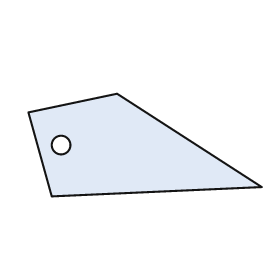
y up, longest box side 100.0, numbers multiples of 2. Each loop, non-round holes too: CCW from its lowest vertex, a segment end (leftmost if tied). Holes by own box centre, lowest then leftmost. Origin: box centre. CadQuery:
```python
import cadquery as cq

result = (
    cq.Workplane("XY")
    .moveTo(-40.0, -22.0)
    .lineTo(50.0, -18.0)
    .lineTo(-12.0, 22.0)
    .lineTo(-50.0, 14.0)
    .close()
    .moveTo(-36.0, 0.0)
    .circle(4.0)
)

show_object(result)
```